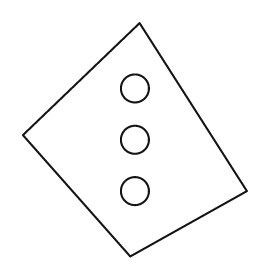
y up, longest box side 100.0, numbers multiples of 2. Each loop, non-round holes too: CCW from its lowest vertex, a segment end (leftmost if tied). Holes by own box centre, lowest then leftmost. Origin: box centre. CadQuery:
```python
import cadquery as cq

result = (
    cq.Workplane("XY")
    .moveTo(-2.0, -50.0)
    .lineTo(48.0, -22.0)
    .lineTo(2.0, 50.0)
    .lineTo(-48.0, 2.0)
    .close()
    .moveTo(0.0, -22.0)
    .circle(6.0)
    .moveTo(0.0, 0.0)
    .circle(6.0)
    .moveTo(0.0, 22.0)
    .circle(6.0)
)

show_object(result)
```